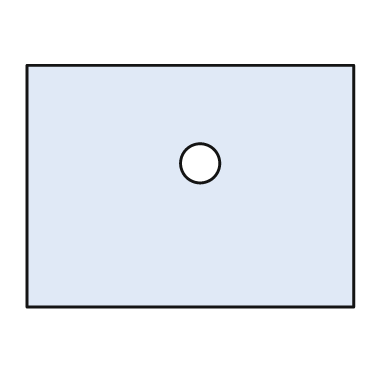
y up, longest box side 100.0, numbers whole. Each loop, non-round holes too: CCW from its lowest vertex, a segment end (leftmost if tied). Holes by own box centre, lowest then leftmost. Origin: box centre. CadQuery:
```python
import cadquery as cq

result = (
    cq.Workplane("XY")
    .moveTo(-50.0, -37.0)
    .lineTo(50.0, -37.0)
    .lineTo(50.0, 37.0)
    .lineTo(-50.0, 37.0)
    .close()
    .moveTo(3.0, 7.0)
    .circle(6.0)
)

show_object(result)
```